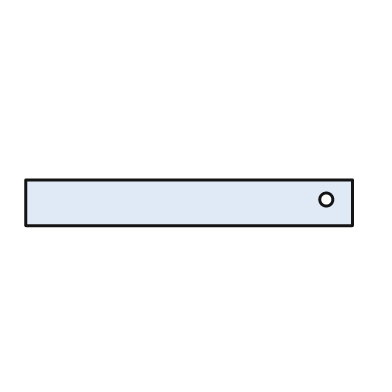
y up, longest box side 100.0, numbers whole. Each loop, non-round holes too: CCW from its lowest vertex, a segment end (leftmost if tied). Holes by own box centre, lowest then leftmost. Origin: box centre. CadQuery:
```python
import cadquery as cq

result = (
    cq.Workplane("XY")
    .moveTo(-50.0, -7.0)
    .lineTo(50.0, -7.0)
    .lineTo(50.0, 7.0)
    .lineTo(-50.0, 7.0)
    .close()
    .moveTo(42.0, 1.0)
    .circle(2.0)
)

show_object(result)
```